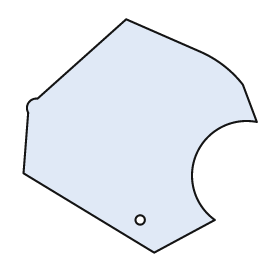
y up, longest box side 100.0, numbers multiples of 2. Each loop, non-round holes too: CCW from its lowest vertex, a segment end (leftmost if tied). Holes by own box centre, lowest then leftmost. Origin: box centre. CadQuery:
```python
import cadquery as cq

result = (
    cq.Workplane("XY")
    .moveTo(6.0, -50.0)
    .lineTo(32.0, -36.0)
    .threePointArc((24.0, -8.0), (50.0, 6.0))
    .lineTo(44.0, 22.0)
    .threePointArc((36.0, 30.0), (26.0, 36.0))
    .lineTo(-6.0, 50.0)
    .lineTo(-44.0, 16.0)
    .threePointArc((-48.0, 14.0), (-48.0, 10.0))
    .lineTo(-50.0, -16.0)
    .close()
    .moveTo(0.0, -36.0)
    .circle(2.0)
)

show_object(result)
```